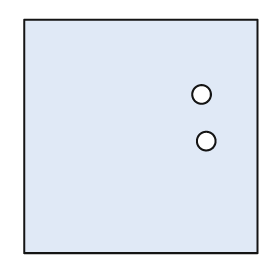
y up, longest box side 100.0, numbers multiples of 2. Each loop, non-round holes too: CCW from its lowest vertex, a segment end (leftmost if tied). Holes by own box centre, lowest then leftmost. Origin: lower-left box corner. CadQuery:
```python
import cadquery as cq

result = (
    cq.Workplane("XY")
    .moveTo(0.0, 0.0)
    .lineTo(100.0, 0.0)
    .lineTo(100.0, 100.0)
    .lineTo(0.0, 100.0)
    .close()
    .moveTo(78.0, 48.0)
    .circle(4.0)
    .moveTo(76.0, 68.0)
    .circle(4.0)
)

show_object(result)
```